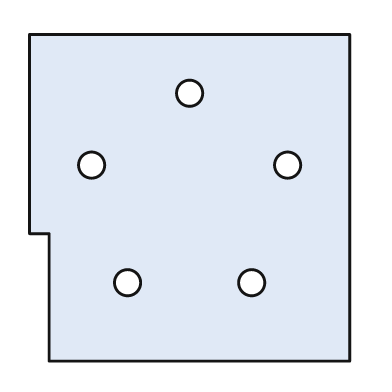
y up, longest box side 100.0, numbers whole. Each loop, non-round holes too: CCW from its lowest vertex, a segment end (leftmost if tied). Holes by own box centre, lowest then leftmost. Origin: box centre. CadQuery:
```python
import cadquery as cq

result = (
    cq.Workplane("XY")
    .moveTo(-43.0, -50.0)
    .lineTo(49.0, -50.0)
    .lineTo(49.0, 50.0)
    .lineTo(-49.0, 50.0)
    .lineTo(-49.0, -11.0)
    .lineTo(-43.0, -11.0)
    .close()
    .moveTo(-19.0, -26.0)
    .circle(4.0)
    .moveTo(19.0, -26.0)
    .circle(4.0)
    .moveTo(-30.0, 10.0)
    .circle(4.0)
    .moveTo(30.0, 10.0)
    .circle(4.0)
    .moveTo(0.0, 32.0)
    .circle(4.0)
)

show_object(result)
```